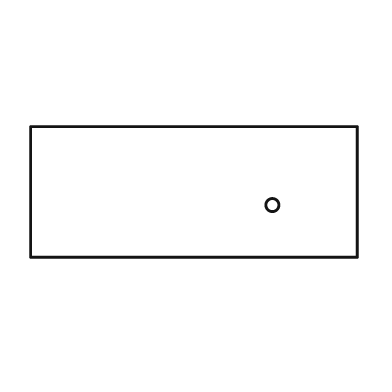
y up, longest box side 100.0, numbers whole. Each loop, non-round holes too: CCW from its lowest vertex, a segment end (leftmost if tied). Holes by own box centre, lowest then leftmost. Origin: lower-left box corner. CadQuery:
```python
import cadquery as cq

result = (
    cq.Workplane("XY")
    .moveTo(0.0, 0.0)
    .lineTo(100.0, 0.0)
    .lineTo(100.0, 40.0)
    .lineTo(0.0, 40.0)
    .close()
    .moveTo(74.0, 16.0)
    .circle(2.0)
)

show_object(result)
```